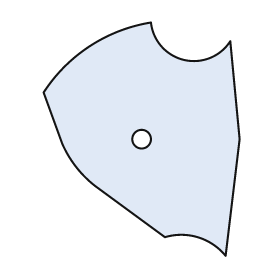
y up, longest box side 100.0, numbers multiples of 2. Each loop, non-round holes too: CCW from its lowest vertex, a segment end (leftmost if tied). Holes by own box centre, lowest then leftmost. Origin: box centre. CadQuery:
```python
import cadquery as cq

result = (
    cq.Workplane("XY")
    .moveTo(36.0, -50.0)
    .lineTo(42.0, 0.0)
    .lineTo(38.0, 42.0)
    .threePointArc((18.0, 34.0), (4.0, 50.0))
    .threePointArc((-22.0, 40.0), (-42.0, 20.0))
    .lineTo(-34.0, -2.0)
    .threePointArc((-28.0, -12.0), (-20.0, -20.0))
    .lineTo(10.0, -42.0)
    .threePointArc((24.0, -42.0), (36.0, -50.0))
    .close()
    .moveTo(0.0, 0.0)
    .circle(4.0)
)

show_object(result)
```